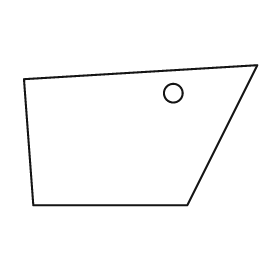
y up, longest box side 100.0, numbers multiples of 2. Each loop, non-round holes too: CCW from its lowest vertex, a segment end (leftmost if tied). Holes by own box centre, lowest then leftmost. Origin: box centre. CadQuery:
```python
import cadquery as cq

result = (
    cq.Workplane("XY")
    .moveTo(-46.0, -30.0)
    .lineTo(20.0, -30.0)
    .lineTo(50.0, 30.0)
    .lineTo(-50.0, 24.0)
    .close()
    .moveTo(14.0, 18.0)
    .circle(4.0)
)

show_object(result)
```